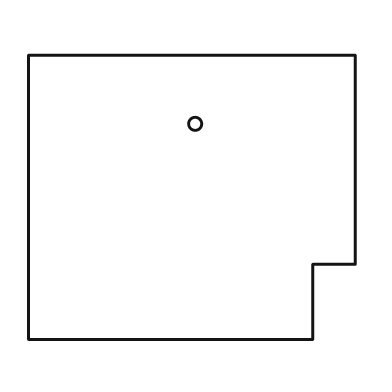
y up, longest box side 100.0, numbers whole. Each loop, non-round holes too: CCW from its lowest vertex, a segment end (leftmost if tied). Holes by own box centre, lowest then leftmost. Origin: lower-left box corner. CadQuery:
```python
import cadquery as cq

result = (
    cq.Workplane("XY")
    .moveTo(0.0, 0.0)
    .lineTo(87.0, 0.0)
    .lineTo(87.0, 23.0)
    .lineTo(100.0, 23.0)
    .lineTo(100.0, 87.0)
    .lineTo(0.0, 87.0)
    .close()
    .moveTo(51.0, 66.0)
    .circle(2.0)
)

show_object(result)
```